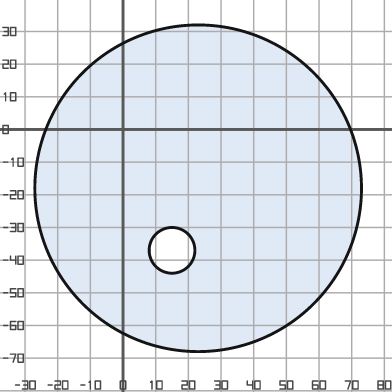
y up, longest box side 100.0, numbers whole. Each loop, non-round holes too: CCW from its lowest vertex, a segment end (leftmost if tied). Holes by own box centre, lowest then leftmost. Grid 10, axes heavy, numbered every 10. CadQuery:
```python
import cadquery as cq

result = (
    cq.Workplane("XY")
    .moveTo(23.0, -18.0)
    .circle(50.0)
    .moveTo(15.0, -37.0)
    .circle(7.0)
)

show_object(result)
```